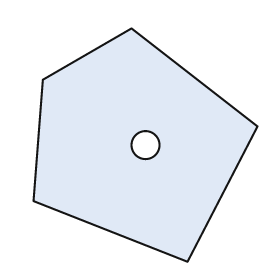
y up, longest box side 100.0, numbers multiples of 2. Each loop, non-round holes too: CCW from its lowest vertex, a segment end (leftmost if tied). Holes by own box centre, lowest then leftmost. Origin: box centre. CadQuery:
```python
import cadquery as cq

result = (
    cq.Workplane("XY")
    .moveTo(18.0, -50.0)
    .lineTo(48.0, 8.0)
    .lineTo(-6.0, 50.0)
    .lineTo(-44.0, 28.0)
    .lineTo(-48.0, -24.0)
    .close()
    .moveTo(0.0, 0.0)
    .circle(6.0)
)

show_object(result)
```